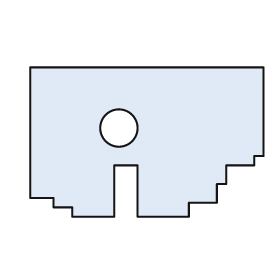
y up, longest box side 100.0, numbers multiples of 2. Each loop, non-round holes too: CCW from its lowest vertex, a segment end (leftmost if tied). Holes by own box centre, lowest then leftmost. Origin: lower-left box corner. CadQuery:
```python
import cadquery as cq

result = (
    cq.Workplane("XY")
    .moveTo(18.0, 0.0)
    .lineTo(36.0, 0.0)
    .lineTo(36.0, 22.0)
    .lineTo(46.0, 22.0)
    .lineTo(46.0, 0.0)
    .lineTo(68.0, 0.0)
    .lineTo(68.0, 6.0)
    .lineTo(80.0, 6.0)
    .lineTo(80.0, 14.0)
    .lineTo(84.0, 14.0)
    .lineTo(84.0, 22.0)
    .lineTo(96.0, 22.0)
    .lineTo(96.0, 26.0)
    .lineTo(100.0, 26.0)
    .lineTo(100.0, 64.0)
    .lineTo(0.0, 64.0)
    .lineTo(0.0, 8.0)
    .lineTo(10.0, 8.0)
    .lineTo(10.0, 4.0)
    .lineTo(18.0, 4.0)
    .close()
    .moveTo(38.0, 38.0)
    .circle(8.0)
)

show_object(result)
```